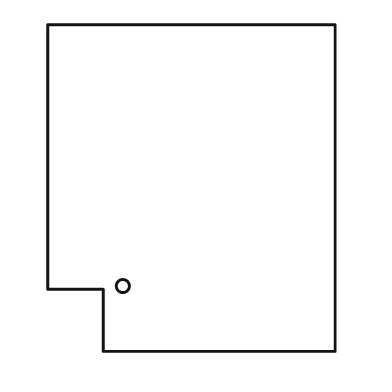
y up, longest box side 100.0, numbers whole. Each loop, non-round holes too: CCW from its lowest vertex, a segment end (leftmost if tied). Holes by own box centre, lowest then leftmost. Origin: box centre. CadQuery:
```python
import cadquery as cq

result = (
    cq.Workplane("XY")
    .moveTo(-27.0, -50.0)
    .lineTo(44.0, -50.0)
    .lineTo(44.0, 50.0)
    .lineTo(-44.0, 50.0)
    .lineTo(-44.0, -31.0)
    .lineTo(-27.0, -31.0)
    .close()
    .moveTo(-21.0, -30.0)
    .circle(2.0)
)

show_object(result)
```